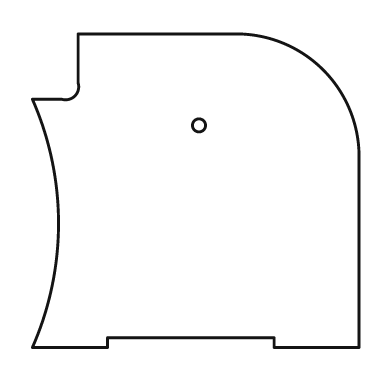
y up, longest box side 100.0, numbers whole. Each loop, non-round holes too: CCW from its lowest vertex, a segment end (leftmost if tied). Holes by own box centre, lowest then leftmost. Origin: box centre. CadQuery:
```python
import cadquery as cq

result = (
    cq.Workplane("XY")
    .moveTo(-50.0, -48.0)
    .lineTo(-27.0, -48.0)
    .lineTo(-27.0, -45.0)
    .lineTo(24.0, -45.0)
    .lineTo(24.0, -48.0)
    .lineTo(50.0, -48.0)
    .lineTo(50.0, 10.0)
    .threePointArc((39.0, 37.0), (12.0, 48.0))
    .lineTo(-36.0, 48.0)
    .lineTo(-36.0, 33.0)
    .threePointArc((-37.0, 29.0), (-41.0, 28.0))
    .lineTo(-50.0, 28.0)
    .threePointArc((-42.0, -10.0), (-50.0, -48.0))
    .close()
    .moveTo(1.0, 20.0)
    .circle(2.0)
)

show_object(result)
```